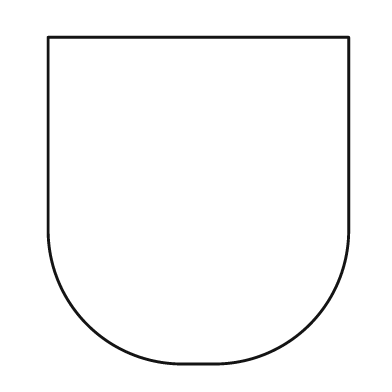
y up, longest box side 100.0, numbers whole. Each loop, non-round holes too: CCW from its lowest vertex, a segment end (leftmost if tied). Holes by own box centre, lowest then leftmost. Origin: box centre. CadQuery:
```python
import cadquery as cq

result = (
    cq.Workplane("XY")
    .moveTo(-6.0, -50.0)
    .lineTo(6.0, -50.0)
    .threePointArc((34.0, -38.0), (46.0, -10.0))
    .lineTo(46.0, 50.0)
    .lineTo(-46.0, 50.0)
    .lineTo(-46.0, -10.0)
    .threePointArc((-34.0, -38.0), (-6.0, -50.0))
    .close()
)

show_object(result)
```